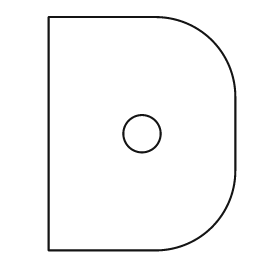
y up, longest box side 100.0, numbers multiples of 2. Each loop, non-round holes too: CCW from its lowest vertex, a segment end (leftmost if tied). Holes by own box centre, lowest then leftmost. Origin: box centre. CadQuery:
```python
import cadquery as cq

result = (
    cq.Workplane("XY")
    .moveTo(-40.0, -50.0)
    .lineTo(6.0, -50.0)
    .threePointArc((30.0, -40.0), (40.0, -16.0))
    .lineTo(40.0, 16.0)
    .threePointArc((30.0, 40.0), (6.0, 50.0))
    .lineTo(-40.0, 50.0)
    .close()
    .moveTo(0.0, 0.0)
    .circle(8.0)
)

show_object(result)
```